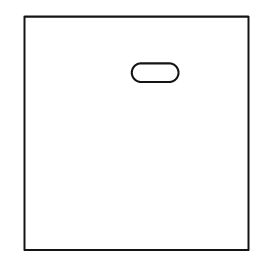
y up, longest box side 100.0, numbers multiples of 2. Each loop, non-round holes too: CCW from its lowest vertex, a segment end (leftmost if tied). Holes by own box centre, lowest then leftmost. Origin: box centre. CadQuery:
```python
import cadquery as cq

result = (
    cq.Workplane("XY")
    .moveTo(-48.0, -50.0)
    .lineTo(48.0, -50.0)
    .lineTo(48.0, 50.0)
    .lineTo(-48.0, 50.0)
    .close()
    .moveTo(2.0, 22.0)
    .lineTo(14.0, 22.0)
    .threePointArc((18.0, 26.0), (14.0, 30.0))
    .lineTo(2.0, 30.0)
    .threePointArc((-2.0, 26.0), (2.0, 22.0))
    .close()
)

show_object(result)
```